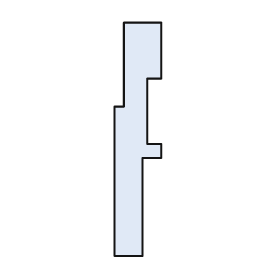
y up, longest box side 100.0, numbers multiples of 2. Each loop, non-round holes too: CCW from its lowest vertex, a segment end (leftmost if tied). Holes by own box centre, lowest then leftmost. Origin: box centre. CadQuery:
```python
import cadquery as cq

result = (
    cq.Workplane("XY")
    .moveTo(-10.0, -50.0)
    .lineTo(2.0, -50.0)
    .lineTo(2.0, -8.0)
    .lineTo(10.0, -8.0)
    .lineTo(10.0, -2.0)
    .lineTo(4.0, -2.0)
    .lineTo(4.0, 26.0)
    .lineTo(10.0, 26.0)
    .lineTo(10.0, 50.0)
    .lineTo(-6.0, 50.0)
    .lineTo(-6.0, 14.0)
    .lineTo(-10.0, 14.0)
    .close()
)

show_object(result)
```